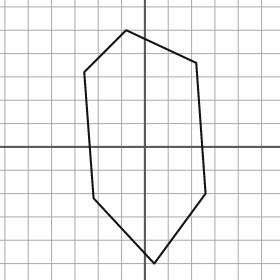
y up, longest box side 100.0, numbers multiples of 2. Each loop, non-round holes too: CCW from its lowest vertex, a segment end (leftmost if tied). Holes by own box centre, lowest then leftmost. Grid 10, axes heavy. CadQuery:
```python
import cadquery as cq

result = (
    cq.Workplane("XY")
    .moveTo(4.0, -50.0)
    .lineTo(26.0, -20.0)
    .lineTo(22.0, 36.0)
    .lineTo(-8.0, 50.0)
    .lineTo(-26.0, 32.0)
    .lineTo(-22.0, -22.0)
    .close()
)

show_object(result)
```